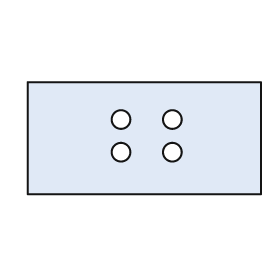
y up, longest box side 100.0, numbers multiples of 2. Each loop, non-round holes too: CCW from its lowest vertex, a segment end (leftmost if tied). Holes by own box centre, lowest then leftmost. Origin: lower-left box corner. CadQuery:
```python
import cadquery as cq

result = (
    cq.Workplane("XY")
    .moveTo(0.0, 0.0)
    .lineTo(100.0, 0.0)
    .lineTo(100.0, 48.0)
    .lineTo(0.0, 48.0)
    .close()
    .moveTo(40.0, 18.0)
    .circle(4.0)
    .moveTo(62.0, 18.0)
    .circle(4.0)
    .moveTo(40.0, 32.0)
    .circle(4.0)
    .moveTo(62.0, 32.0)
    .circle(4.0)
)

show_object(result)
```